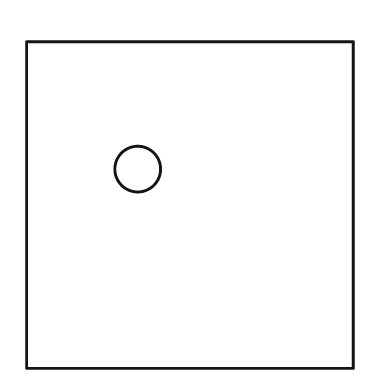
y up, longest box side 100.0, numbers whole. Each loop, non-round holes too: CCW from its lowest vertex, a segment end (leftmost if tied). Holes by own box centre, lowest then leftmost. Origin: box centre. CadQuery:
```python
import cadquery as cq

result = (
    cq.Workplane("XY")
    .moveTo(-50.0, -50.0)
    .lineTo(50.0, -50.0)
    .lineTo(50.0, 50.0)
    .lineTo(-50.0, 50.0)
    .close()
    .moveTo(-16.0, 11.0)
    .circle(7.0)
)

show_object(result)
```